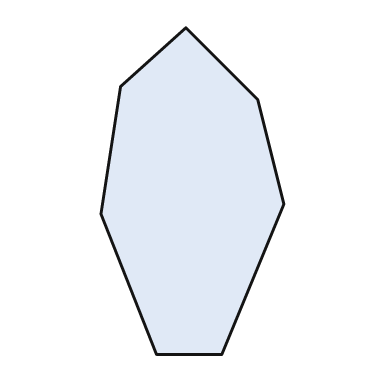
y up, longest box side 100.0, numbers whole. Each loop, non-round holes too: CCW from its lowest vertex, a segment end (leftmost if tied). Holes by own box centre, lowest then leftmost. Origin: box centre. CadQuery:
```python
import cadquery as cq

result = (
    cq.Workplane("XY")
    .moveTo(-11.0, -50.0)
    .lineTo(9.0, -50.0)
    .lineTo(28.0, -4.0)
    .lineTo(20.0, 28.0)
    .lineTo(-2.0, 50.0)
    .lineTo(-22.0, 32.0)
    .lineTo(-28.0, -7.0)
    .close()
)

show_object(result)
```